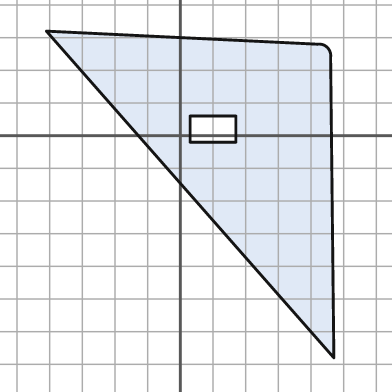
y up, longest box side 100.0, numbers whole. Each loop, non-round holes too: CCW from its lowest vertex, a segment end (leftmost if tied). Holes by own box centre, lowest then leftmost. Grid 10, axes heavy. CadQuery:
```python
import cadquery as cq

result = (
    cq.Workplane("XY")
    .moveTo(47.0, -68.0)
    .lineTo(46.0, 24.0)
    .threePointArc((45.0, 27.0), (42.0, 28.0))
    .lineTo(-41.0, 32.0)
    .close()
    .moveTo(3.0, -2.0)
    .lineTo(17.0, -2.0)
    .lineTo(17.0, 6.0)
    .lineTo(3.0, 6.0)
    .close()
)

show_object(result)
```